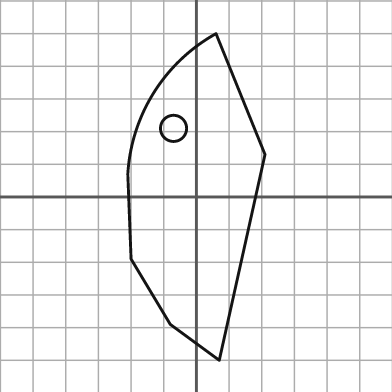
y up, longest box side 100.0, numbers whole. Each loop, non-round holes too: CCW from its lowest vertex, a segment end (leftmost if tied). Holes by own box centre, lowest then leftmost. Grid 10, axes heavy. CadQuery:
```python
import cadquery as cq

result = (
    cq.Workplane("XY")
    .moveTo(7.0, -50.0)
    .lineTo(21.0, 13.0)
    .lineTo(6.0, 50.0)
    .threePointArc((-13.0, 32.0), (-21.0, 7.0))
    .lineTo(-20.0, -19.0)
    .lineTo(-8.0, -39.0)
    .close()
    .moveTo(-7.0, 21.0)
    .circle(4.0)
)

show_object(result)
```